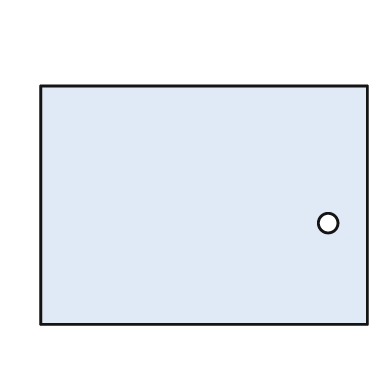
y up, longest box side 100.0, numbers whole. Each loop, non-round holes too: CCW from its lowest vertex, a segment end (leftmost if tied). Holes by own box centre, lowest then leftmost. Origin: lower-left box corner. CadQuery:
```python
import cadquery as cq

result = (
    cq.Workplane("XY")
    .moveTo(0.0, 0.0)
    .lineTo(100.0, 0.0)
    .lineTo(100.0, 73.0)
    .lineTo(0.0, 73.0)
    .close()
    .moveTo(88.0, 31.0)
    .circle(3.0)
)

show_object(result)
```